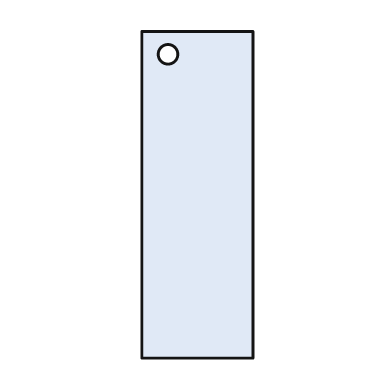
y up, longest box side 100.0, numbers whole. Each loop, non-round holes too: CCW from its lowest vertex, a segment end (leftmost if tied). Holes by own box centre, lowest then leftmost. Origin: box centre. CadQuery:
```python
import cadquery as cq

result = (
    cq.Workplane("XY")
    .moveTo(-17.0, -50.0)
    .lineTo(17.0, -50.0)
    .lineTo(17.0, 50.0)
    .lineTo(-17.0, 50.0)
    .close()
    .moveTo(-9.0, 43.0)
    .circle(3.0)
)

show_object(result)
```